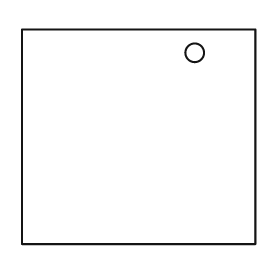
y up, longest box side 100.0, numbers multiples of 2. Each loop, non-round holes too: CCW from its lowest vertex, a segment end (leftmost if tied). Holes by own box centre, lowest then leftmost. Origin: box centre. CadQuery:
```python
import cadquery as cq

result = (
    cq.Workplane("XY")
    .moveTo(-50.0, -46.0)
    .lineTo(50.0, -46.0)
    .lineTo(50.0, 46.0)
    .lineTo(-50.0, 46.0)
    .close()
    .moveTo(24.0, 36.0)
    .circle(4.0)
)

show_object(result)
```